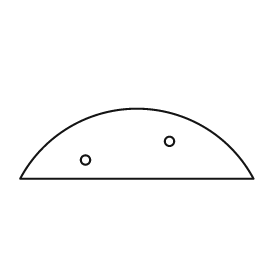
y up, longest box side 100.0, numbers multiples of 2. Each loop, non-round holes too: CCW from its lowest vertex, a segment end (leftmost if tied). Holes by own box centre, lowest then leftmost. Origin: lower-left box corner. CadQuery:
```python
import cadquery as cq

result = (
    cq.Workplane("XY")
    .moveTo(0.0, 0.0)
    .lineTo(100.0, 0.0)
    .threePointArc((50.0, 30.0), (0.0, 0.0))
    .close()
    .moveTo(28.0, 8.0)
    .circle(2.0)
    .moveTo(64.0, 16.0)
    .circle(2.0)
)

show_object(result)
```